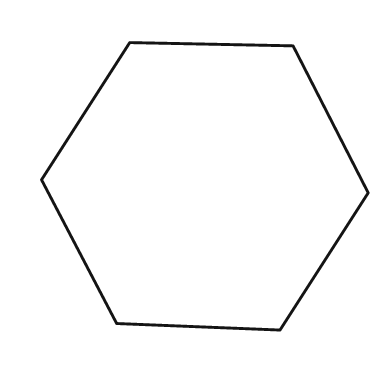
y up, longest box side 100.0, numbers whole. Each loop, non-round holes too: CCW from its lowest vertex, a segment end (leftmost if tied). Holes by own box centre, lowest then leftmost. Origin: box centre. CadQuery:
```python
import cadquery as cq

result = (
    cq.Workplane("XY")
    .moveTo(23.0, -44.0)
    .lineTo(50.0, -2.0)
    .lineTo(27.0, 43.0)
    .lineTo(-23.0, 44.0)
    .lineTo(-50.0, 2.0)
    .lineTo(-27.0, -42.0)
    .close()
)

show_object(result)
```